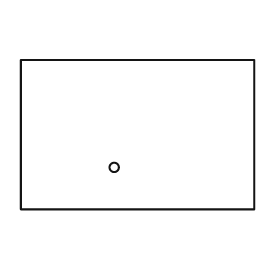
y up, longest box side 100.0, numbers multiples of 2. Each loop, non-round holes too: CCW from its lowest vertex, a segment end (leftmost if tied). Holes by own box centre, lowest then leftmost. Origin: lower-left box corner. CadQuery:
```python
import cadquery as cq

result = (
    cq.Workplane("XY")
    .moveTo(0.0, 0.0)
    .lineTo(100.0, 0.0)
    .lineTo(100.0, 64.0)
    .lineTo(0.0, 64.0)
    .close()
    .moveTo(40.0, 18.0)
    .circle(2.0)
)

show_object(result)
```